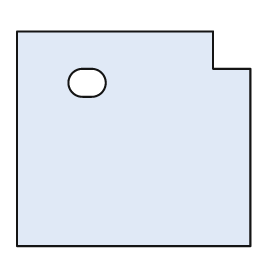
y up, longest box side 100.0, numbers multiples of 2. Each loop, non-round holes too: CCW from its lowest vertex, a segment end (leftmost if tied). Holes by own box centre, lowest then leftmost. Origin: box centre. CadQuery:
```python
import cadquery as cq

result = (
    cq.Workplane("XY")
    .moveTo(-50.0, -46.0)
    .lineTo(50.0, -46.0)
    .lineTo(50.0, 30.0)
    .lineTo(34.0, 30.0)
    .lineTo(34.0, 46.0)
    .lineTo(-50.0, 46.0)
    .close()
    .moveTo(-22.0, 18.0)
    .lineTo(-18.0, 18.0)
    .threePointArc((-12.0, 24.0), (-18.0, 30.0))
    .lineTo(-22.0, 30.0)
    .threePointArc((-28.0, 24.0), (-22.0, 18.0))
    .close()
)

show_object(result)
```